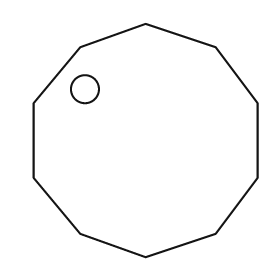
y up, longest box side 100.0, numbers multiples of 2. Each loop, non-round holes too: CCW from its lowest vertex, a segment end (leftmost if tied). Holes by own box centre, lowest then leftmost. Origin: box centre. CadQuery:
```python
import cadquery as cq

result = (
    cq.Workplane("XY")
    .moveTo(0.0, -50.0)
    .lineTo(30.0, -40.0)
    .lineTo(48.0, -16.0)
    .lineTo(48.0, 16.0)
    .lineTo(30.0, 40.0)
    .lineTo(0.0, 50.0)
    .lineTo(-28.0, 40.0)
    .lineTo(-48.0, 16.0)
    .lineTo(-48.0, -16.0)
    .lineTo(-28.0, -40.0)
    .close()
    .moveTo(-26.0, 22.0)
    .circle(6.0)
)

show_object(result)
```